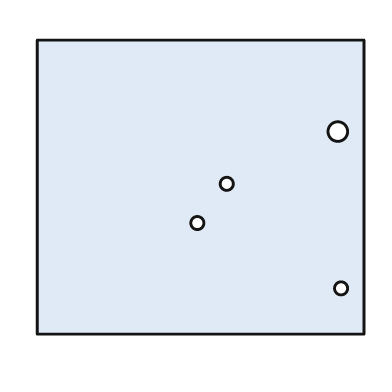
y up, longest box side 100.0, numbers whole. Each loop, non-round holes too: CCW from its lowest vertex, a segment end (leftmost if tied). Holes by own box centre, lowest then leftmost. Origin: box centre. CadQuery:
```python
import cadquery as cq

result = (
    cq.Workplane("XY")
    .moveTo(-50.0, -45.0)
    .lineTo(50.0, -45.0)
    .lineTo(50.0, 45.0)
    .lineTo(-50.0, 45.0)
    .close()
    .moveTo(43.0, -31.0)
    .circle(2.0)
    .moveTo(-1.0, -11.0)
    .circle(2.0)
    .moveTo(8.0, 1.0)
    .circle(2.0)
    .moveTo(42.0, 17.0)
    .circle(3.0)
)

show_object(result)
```